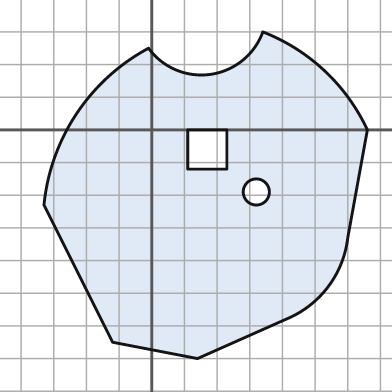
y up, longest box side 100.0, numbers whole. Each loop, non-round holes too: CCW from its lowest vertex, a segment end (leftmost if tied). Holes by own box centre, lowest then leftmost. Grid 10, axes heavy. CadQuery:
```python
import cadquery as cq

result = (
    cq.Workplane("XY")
    .moveTo(14.0, -70.0)
    .lineTo(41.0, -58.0)
    .threePointArc((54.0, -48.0), (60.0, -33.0))
    .lineTo(66.0, 0.0)
    .threePointArc((53.0, 18.0), (34.0, 30.0))
    .threePointArc((18.0, 17.0), (-1.0, 25.0))
    .threePointArc((-23.0, 5.0), (-33.0, -23.0))
    .lineTo(-12.0, -65.0)
    .close()
    .moveTo(32.0, -19.0)
    .circle(4.0)
    .moveTo(11.0, -12.0)
    .lineTo(23.0, -12.0)
    .lineTo(23.0, 0.0)
    .lineTo(11.0, 0.0)
    .close()
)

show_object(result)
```